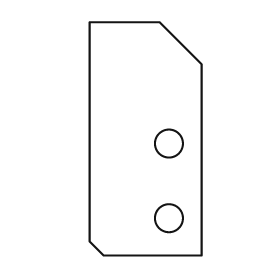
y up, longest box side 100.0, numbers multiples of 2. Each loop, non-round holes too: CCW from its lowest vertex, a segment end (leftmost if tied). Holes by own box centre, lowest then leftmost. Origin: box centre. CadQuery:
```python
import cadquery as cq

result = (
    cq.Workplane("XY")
    .moveTo(-18.0, -50.0)
    .lineTo(24.0, -50.0)
    .lineTo(24.0, 32.0)
    .lineTo(6.0, 50.0)
    .lineTo(-24.0, 50.0)
    .lineTo(-24.0, -44.0)
    .close()
    .moveTo(10.0, -34.0)
    .circle(6.0)
    .moveTo(10.0, -2.0)
    .circle(6.0)
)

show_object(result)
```